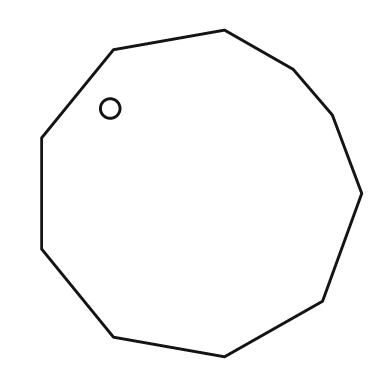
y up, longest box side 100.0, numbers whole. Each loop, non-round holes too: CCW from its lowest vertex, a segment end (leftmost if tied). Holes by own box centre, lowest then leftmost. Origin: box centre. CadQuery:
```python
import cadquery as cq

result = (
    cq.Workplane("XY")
    .moveTo(7.0, -50.0)
    .lineTo(37.0, -33.0)
    .lineTo(49.0, 0.0)
    .lineTo(40.0, 24.0)
    .lineTo(28.0, 38.0)
    .lineTo(7.0, 50.0)
    .lineTo(-27.0, 44.0)
    .lineTo(-49.0, 17.0)
    .lineTo(-49.0, -17.0)
    .lineTo(-27.0, -44.0)
    .close()
    .moveTo(-28.0, 26.0)
    .circle(3.0)
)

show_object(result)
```